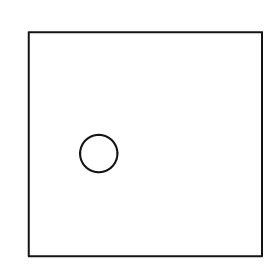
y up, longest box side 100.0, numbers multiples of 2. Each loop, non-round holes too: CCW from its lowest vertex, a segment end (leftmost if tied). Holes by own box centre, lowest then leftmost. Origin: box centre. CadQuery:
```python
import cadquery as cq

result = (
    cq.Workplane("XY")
    .moveTo(-50.0, -48.0)
    .lineTo(50.0, -48.0)
    .lineTo(50.0, 48.0)
    .lineTo(-50.0, 48.0)
    .close()
    .moveTo(-20.0, -4.0)
    .circle(8.0)
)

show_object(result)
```